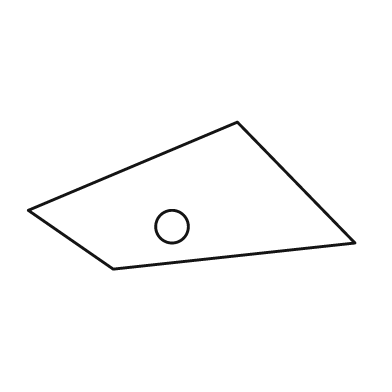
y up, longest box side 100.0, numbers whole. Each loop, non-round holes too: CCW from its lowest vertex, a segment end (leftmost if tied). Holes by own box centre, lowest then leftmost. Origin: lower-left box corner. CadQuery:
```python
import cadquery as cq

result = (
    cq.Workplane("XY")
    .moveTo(26.0, 0.0)
    .lineTo(100.0, 8.0)
    .lineTo(64.0, 45.0)
    .lineTo(0.0, 18.0)
    .close()
    .moveTo(44.0, 13.0)
    .circle(5.0)
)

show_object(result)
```